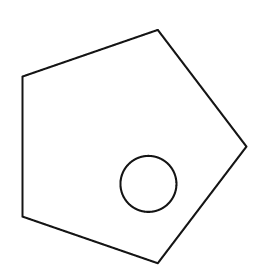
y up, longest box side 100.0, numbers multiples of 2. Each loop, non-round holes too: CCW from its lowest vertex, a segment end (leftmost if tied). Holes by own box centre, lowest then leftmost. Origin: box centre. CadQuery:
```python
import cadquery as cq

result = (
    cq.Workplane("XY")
    .moveTo(10.0, -50.0)
    .lineTo(48.0, 0.0)
    .lineTo(10.0, 50.0)
    .lineTo(-48.0, 30.0)
    .lineTo(-48.0, -30.0)
    .close()
    .moveTo(6.0, -16.0)
    .circle(12.0)
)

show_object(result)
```